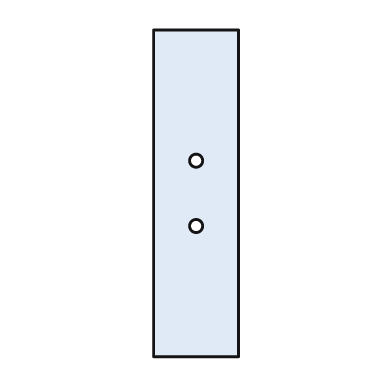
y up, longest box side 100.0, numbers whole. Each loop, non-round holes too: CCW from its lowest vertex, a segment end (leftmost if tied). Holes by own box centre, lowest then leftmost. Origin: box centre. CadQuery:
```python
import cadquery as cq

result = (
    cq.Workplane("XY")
    .moveTo(-13.0, -50.0)
    .lineTo(13.0, -50.0)
    .lineTo(13.0, 50.0)
    .lineTo(-13.0, 50.0)
    .close()
    .moveTo(0.0, -10.0)
    .circle(2.0)
    .moveTo(0.0, 10.0)
    .circle(2.0)
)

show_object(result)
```